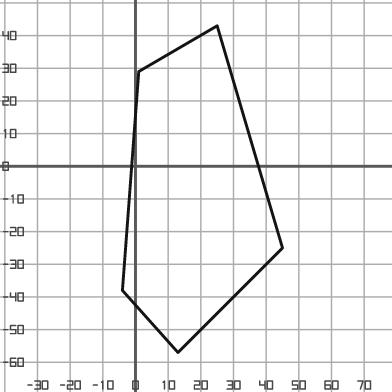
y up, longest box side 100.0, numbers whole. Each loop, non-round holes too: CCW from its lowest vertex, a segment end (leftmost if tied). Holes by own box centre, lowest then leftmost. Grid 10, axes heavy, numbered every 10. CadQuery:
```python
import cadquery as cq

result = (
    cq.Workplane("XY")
    .moveTo(13.0, -57.0)
    .lineTo(45.0, -25.0)
    .lineTo(25.0, 43.0)
    .lineTo(1.0, 29.0)
    .lineTo(-4.0, -38.0)
    .close()
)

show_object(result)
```